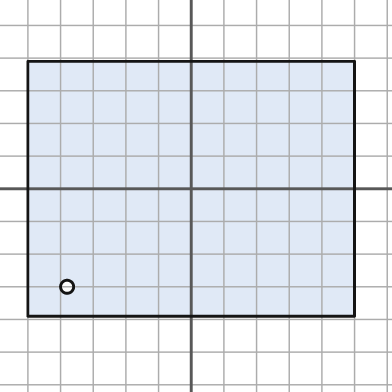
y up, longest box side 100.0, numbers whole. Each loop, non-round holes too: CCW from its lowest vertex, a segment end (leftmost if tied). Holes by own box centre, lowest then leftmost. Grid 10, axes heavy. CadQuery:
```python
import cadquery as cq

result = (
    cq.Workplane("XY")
    .moveTo(-50.0, -39.0)
    .lineTo(50.0, -39.0)
    .lineTo(50.0, 39.0)
    .lineTo(-50.0, 39.0)
    .close()
    .moveTo(-38.0, -30.0)
    .circle(2.0)
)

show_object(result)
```